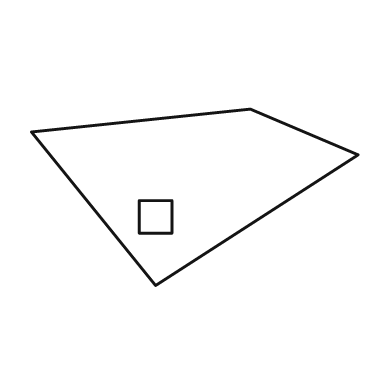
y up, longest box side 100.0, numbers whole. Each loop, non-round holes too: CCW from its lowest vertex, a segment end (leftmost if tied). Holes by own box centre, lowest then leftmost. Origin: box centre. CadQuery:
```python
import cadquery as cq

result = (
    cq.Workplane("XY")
    .moveTo(-12.0, -27.0)
    .lineTo(50.0, 13.0)
    .lineTo(17.0, 27.0)
    .lineTo(-50.0, 20.0)
    .close()
    .moveTo(-17.0, -11.0)
    .lineTo(-7.0, -11.0)
    .lineTo(-7.0, -1.0)
    .lineTo(-17.0, -1.0)
    .close()
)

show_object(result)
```